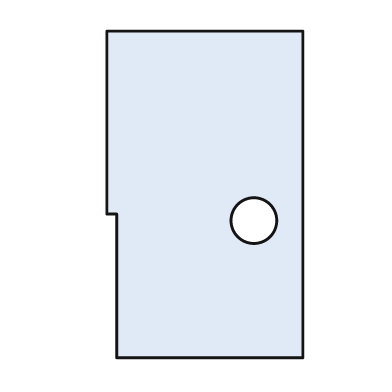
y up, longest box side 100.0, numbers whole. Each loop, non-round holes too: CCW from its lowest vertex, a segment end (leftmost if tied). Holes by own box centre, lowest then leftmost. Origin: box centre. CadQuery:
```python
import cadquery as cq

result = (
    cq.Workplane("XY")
    .moveTo(-27.0, -50.0)
    .lineTo(30.0, -50.0)
    .lineTo(30.0, 50.0)
    .lineTo(-30.0, 50.0)
    .lineTo(-30.0, -6.0)
    .lineTo(-27.0, -6.0)
    .close()
    .moveTo(15.0, -8.0)
    .circle(7.0)
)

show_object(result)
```